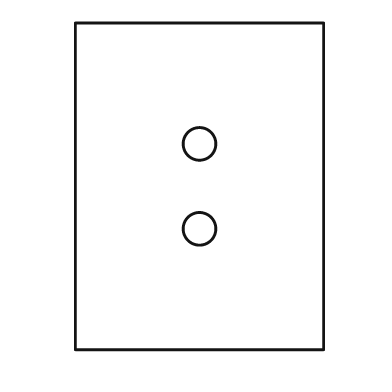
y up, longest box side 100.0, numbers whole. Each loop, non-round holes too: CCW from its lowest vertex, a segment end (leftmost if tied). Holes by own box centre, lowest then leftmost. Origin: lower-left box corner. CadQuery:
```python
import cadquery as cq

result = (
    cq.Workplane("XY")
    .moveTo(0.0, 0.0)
    .lineTo(76.0, 0.0)
    .lineTo(76.0, 100.0)
    .lineTo(0.0, 100.0)
    .close()
    .moveTo(38.0, 37.0)
    .circle(5.0)
    .moveTo(38.0, 63.0)
    .circle(5.0)
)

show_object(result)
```